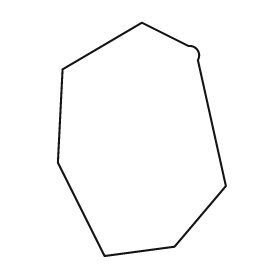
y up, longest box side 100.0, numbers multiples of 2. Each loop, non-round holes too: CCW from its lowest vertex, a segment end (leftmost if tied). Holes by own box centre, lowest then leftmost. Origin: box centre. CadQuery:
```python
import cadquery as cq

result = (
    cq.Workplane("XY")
    .moveTo(-16.0, -50.0)
    .lineTo(14.0, -46.0)
    .lineTo(36.0, -20.0)
    .lineTo(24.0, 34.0)
    .threePointArc((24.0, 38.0), (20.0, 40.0))
    .lineTo(0.0, 50.0)
    .lineTo(-34.0, 30.0)
    .lineTo(-36.0, -10.0)
    .close()
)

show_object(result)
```